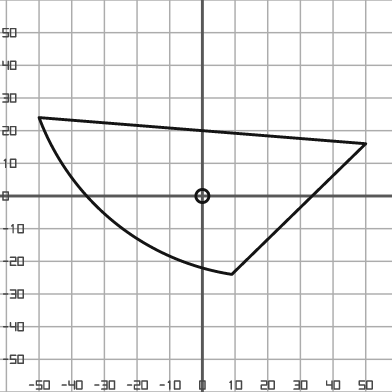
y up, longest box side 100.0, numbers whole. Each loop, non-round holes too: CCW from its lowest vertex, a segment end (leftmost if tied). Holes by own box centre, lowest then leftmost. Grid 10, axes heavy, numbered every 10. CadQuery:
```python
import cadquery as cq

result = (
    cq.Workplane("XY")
    .moveTo(9.0, -24.0)
    .lineTo(50.0, 16.0)
    .lineTo(-50.0, 24.0)
    .threePointArc((-27.0, -8.0), (9.0, -24.0))
    .close()
    .moveTo(0.0, 0.0)
    .circle(2.0)
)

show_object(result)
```